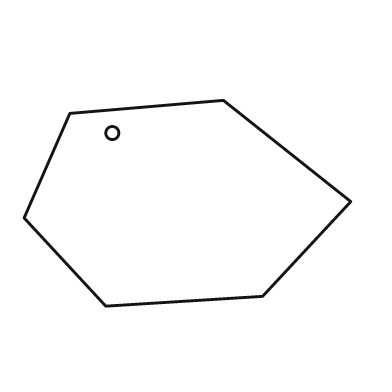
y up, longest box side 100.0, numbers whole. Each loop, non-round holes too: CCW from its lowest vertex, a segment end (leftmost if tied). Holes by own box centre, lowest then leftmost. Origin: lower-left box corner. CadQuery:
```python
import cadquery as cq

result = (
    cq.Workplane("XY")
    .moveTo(25.0, 0.0)
    .lineTo(73.0, 3.0)
    .lineTo(100.0, 32.0)
    .lineTo(61.0, 63.0)
    .lineTo(14.0, 59.0)
    .lineTo(0.0, 27.0)
    .close()
    .moveTo(27.0, 53.0)
    .circle(2.0)
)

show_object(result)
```